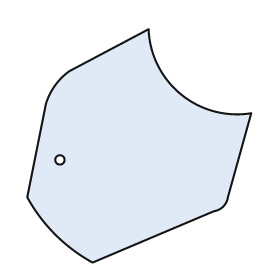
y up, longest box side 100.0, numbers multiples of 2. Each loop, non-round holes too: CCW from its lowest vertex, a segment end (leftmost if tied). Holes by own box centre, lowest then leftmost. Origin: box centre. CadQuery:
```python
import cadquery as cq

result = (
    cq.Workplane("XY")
    .moveTo(-20.0, -50.0)
    .lineTo(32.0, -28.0)
    .threePointArc((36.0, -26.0), (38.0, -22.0))
    .lineTo(48.0, 14.0)
    .threePointArc((18.0, 22.0), (4.0, 50.0))
    .lineTo(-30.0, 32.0)
    .threePointArc((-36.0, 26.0), (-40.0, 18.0))
    .lineTo(-48.0, -22.0)
    .threePointArc((-36.0, -38.0), (-20.0, -50.0))
    .close()
    .moveTo(-34.0, -6.0)
    .circle(2.0)
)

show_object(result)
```